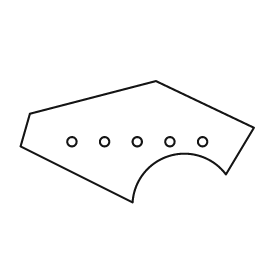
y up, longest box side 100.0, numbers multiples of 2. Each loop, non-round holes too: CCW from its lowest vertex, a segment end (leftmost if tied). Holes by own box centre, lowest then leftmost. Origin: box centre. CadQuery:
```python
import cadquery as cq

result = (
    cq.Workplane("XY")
    .moveTo(-2.0, -26.0)
    .threePointArc((14.0, -6.0), (38.0, -14.0))
    .lineTo(50.0, 6.0)
    .lineTo(8.0, 26.0)
    .lineTo(-46.0, 12.0)
    .lineTo(-50.0, -2.0)
    .close()
    .moveTo(-28.0, 0.0)
    .circle(2.0)
    .moveTo(-14.0, 0.0)
    .circle(2.0)
    .moveTo(0.0, 0.0)
    .circle(2.0)
    .moveTo(14.0, 0.0)
    .circle(2.0)
    .moveTo(28.0, 0.0)
    .circle(2.0)
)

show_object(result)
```